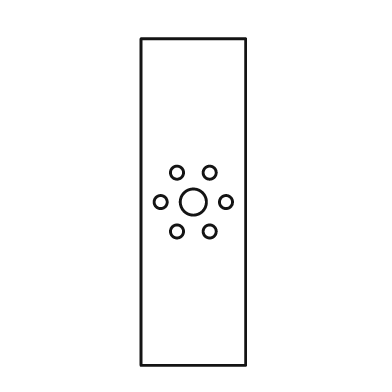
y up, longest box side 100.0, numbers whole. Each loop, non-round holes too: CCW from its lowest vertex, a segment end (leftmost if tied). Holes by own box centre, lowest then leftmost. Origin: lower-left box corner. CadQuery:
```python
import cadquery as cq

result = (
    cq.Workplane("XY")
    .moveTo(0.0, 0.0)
    .lineTo(32.0, 0.0)
    .lineTo(32.0, 100.0)
    .lineTo(0.0, 100.0)
    .close()
    .moveTo(11.0, 41.0)
    .circle(2.0)
    .moveTo(21.0, 41.0)
    .circle(2.0)
    .moveTo(6.0, 50.0)
    .circle(2.0)
    .moveTo(16.0, 50.0)
    .circle(4.0)
    .moveTo(26.0, 50.0)
    .circle(2.0)
    .moveTo(11.0, 59.0)
    .circle(2.0)
    .moveTo(21.0, 59.0)
    .circle(2.0)
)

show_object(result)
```